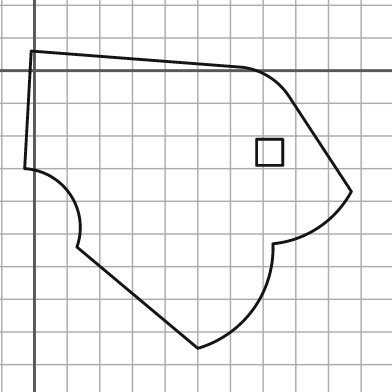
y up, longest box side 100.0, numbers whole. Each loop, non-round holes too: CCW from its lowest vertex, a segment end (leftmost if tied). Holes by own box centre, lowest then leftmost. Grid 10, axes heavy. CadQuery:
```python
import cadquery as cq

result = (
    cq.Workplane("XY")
    .moveTo(50.0, -85.0)
    .threePointArc((67.0, -73.0), (73.0, -53.0))
    .threePointArc((87.0, -48.0), (97.0, -37.0))
    .lineTo(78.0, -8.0)
    .threePointArc((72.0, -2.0), (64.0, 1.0))
    .lineTo(-1.0, 6.0)
    .lineTo(-3.0, -30.0)
    .threePointArc((11.0, -38.0), (13.0, -54.0))
    .close()
    .moveTo(68.0, -29.0)
    .lineTo(76.0, -29.0)
    .lineTo(76.0, -21.0)
    .lineTo(68.0, -21.0)
    .close()
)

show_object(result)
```